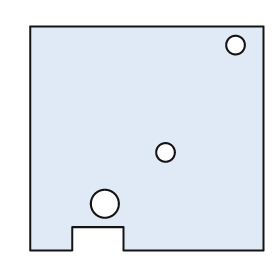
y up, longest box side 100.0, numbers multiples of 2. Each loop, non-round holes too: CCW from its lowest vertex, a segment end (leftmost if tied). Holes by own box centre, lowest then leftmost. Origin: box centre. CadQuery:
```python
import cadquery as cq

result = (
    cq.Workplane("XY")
    .moveTo(-50.0, -48.0)
    .lineTo(-32.0, -48.0)
    .lineTo(-32.0, -38.0)
    .lineTo(-10.0, -38.0)
    .lineTo(-10.0, -48.0)
    .lineTo(50.0, -48.0)
    .lineTo(50.0, 48.0)
    .lineTo(-50.0, 48.0)
    .close()
    .moveTo(-18.0, -28.0)
    .circle(6.0)
    .moveTo(8.0, -6.0)
    .circle(4.0)
    .moveTo(38.0, 40.0)
    .circle(4.0)
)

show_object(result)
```